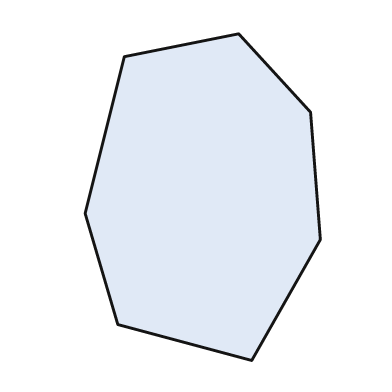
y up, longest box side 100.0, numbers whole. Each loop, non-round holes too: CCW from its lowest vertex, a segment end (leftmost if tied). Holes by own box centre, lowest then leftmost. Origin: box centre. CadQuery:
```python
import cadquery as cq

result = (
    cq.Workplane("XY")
    .moveTo(15.0, -50.0)
    .lineTo(36.0, -13.0)
    .lineTo(33.0, 26.0)
    .lineTo(11.0, 50.0)
    .lineTo(-24.0, 43.0)
    .lineTo(-36.0, -5.0)
    .lineTo(-26.0, -39.0)
    .close()
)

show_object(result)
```